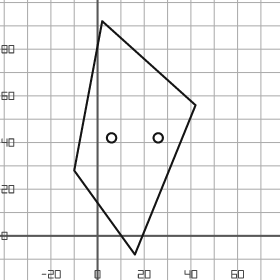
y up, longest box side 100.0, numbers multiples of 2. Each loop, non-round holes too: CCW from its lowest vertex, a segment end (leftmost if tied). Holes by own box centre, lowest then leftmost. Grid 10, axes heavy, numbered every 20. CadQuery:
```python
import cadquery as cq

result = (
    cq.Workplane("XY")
    .moveTo(16.0, -8.0)
    .lineTo(42.0, 56.0)
    .lineTo(2.0, 92.0)
    .lineTo(-10.0, 28.0)
    .close()
    .moveTo(6.0, 42.0)
    .circle(2.0)
    .moveTo(26.0, 42.0)
    .circle(2.0)
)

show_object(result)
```